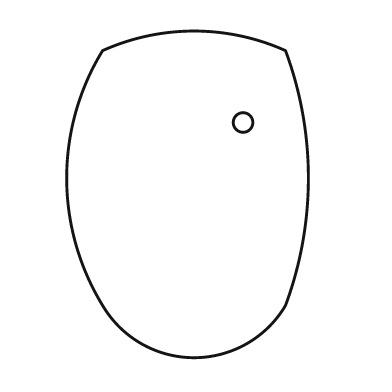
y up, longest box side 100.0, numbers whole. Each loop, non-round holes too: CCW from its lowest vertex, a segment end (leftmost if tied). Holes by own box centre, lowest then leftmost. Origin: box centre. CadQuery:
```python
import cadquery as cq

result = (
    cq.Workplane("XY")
    .moveTo(-26.0, -34.0)
    .threePointArc((2.0, -50.0), (30.0, -34.0))
    .threePointArc((37.0, 5.0), (30.0, 44.0))
    .threePointArc((2.0, 50.0), (-26.0, 44.0))
    .threePointArc((-37.0, 5.0), (-26.0, -34.0))
    .close()
    .moveTo(17.0, 22.0)
    .circle(3.0)
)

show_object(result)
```